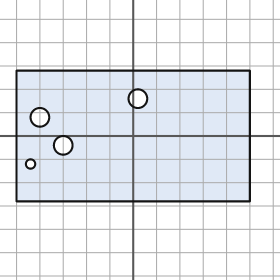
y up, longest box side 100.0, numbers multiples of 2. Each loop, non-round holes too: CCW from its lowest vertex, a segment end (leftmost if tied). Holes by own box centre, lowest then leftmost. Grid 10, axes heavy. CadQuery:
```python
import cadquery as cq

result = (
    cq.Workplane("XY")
    .moveTo(-50.0, -28.0)
    .lineTo(50.0, -28.0)
    .lineTo(50.0, 28.0)
    .lineTo(-50.0, 28.0)
    .close()
    .moveTo(-44.0, -12.0)
    .circle(2.0)
    .moveTo(-30.0, -4.0)
    .circle(4.0)
    .moveTo(-40.0, 8.0)
    .circle(4.0)
    .moveTo(2.0, 16.0)
    .circle(4.0)
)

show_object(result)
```